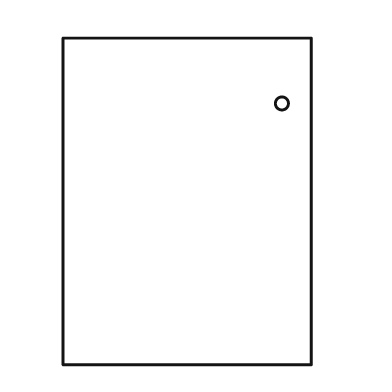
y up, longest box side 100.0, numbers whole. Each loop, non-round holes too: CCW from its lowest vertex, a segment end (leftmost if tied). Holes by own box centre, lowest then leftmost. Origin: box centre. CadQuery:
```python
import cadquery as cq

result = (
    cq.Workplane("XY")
    .moveTo(-38.0, -50.0)
    .lineTo(38.0, -50.0)
    .lineTo(38.0, 50.0)
    .lineTo(-38.0, 50.0)
    .close()
    .moveTo(29.0, 30.0)
    .circle(2.0)
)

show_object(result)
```